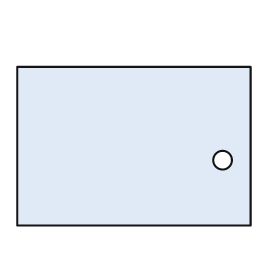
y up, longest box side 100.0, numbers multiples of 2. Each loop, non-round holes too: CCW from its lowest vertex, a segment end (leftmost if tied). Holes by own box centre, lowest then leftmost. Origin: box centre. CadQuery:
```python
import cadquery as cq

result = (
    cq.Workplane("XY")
    .moveTo(-50.0, -34.0)
    .lineTo(50.0, -34.0)
    .lineTo(50.0, 34.0)
    .lineTo(-50.0, 34.0)
    .close()
    .moveTo(38.0, -6.0)
    .circle(4.0)
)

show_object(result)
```